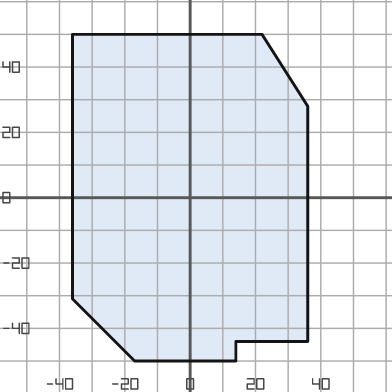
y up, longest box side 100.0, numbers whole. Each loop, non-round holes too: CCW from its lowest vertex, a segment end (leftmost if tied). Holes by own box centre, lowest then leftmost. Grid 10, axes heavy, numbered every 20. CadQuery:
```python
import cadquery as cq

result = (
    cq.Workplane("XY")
    .moveTo(-17.0, -50.0)
    .lineTo(14.0, -50.0)
    .lineTo(14.0, -44.0)
    .lineTo(36.0, -44.0)
    .lineTo(36.0, 28.0)
    .lineTo(22.0, 50.0)
    .lineTo(-36.0, 50.0)
    .lineTo(-36.0, -31.0)
    .close()
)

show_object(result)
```